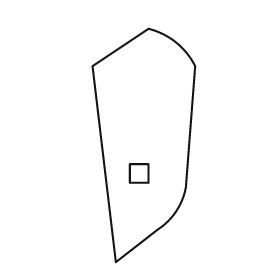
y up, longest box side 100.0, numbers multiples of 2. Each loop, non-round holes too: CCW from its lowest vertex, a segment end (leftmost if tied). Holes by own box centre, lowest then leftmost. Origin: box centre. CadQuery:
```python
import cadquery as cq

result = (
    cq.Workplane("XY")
    .moveTo(-12.0, -50.0)
    .lineTo(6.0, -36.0)
    .threePointArc((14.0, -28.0), (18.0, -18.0))
    .lineTo(22.0, 34.0)
    .threePointArc((14.0, 44.0), (2.0, 50.0))
    .lineTo(-22.0, 34.0)
    .close()
    .moveTo(-6.0, -16.0)
    .lineTo(2.0, -16.0)
    .lineTo(2.0, -8.0)
    .lineTo(-6.0, -8.0)
    .close()
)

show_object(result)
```